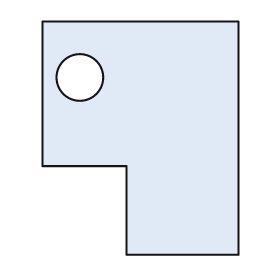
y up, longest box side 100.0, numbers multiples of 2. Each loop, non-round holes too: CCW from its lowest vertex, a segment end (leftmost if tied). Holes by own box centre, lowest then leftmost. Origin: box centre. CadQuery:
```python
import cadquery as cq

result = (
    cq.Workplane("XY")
    .moveTo(-6.0, -50.0)
    .lineTo(42.0, -50.0)
    .lineTo(42.0, 50.0)
    .lineTo(-42.0, 50.0)
    .lineTo(-42.0, -12.0)
    .lineTo(-6.0, -12.0)
    .close()
    .moveTo(-26.0, 26.0)
    .circle(10.0)
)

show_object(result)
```